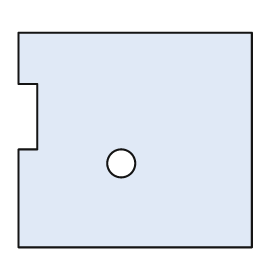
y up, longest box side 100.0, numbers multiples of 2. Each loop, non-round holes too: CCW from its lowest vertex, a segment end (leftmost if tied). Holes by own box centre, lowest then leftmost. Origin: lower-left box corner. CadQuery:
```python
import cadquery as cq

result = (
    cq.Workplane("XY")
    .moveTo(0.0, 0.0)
    .lineTo(100.0, 0.0)
    .lineTo(100.0, 92.0)
    .lineTo(0.0, 92.0)
    .lineTo(0.0, 70.0)
    .lineTo(8.0, 70.0)
    .lineTo(8.0, 42.0)
    .lineTo(0.0, 42.0)
    .close()
    .moveTo(44.0, 36.0)
    .circle(6.0)
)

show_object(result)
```